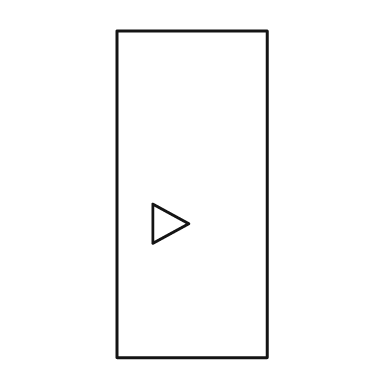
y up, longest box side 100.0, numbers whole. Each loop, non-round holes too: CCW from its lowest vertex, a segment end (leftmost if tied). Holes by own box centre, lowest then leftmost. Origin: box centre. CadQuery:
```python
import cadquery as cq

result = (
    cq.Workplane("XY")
    .moveTo(-23.0, -50.0)
    .lineTo(23.0, -50.0)
    .lineTo(23.0, 50.0)
    .lineTo(-23.0, 50.0)
    .close()
    .moveTo(-12.0, -15.0)
    .lineTo(-1.0, -9.0)
    .lineTo(-12.0, -3.0)
    .close()
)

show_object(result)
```